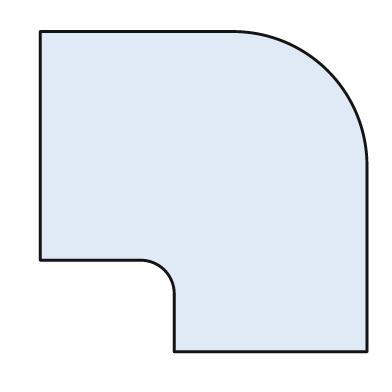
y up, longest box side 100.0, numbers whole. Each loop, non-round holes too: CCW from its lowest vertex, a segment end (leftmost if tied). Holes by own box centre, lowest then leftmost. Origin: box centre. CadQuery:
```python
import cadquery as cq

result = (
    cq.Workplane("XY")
    .moveTo(-9.0, -49.0)
    .lineTo(50.0, -49.0)
    .lineTo(50.0, 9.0)
    .threePointArc((38.0, 37.0), (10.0, 49.0))
    .lineTo(-50.0, 49.0)
    .lineTo(-50.0, -21.0)
    .lineTo(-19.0, -21.0)
    .threePointArc((-12.0, -24.0), (-9.0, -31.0))
    .close()
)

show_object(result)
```